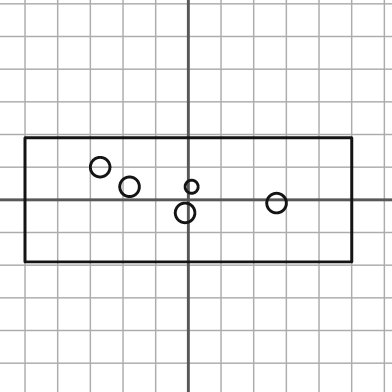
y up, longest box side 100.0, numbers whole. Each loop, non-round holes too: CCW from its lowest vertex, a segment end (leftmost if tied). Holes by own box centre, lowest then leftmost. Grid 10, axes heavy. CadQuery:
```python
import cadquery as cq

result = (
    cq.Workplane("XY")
    .moveTo(-50.0, -19.0)
    .lineTo(50.0, -19.0)
    .lineTo(50.0, 19.0)
    .lineTo(-50.0, 19.0)
    .close()
    .moveTo(-1.0, -4.0)
    .circle(3.0)
    .moveTo(27.0, -1.0)
    .circle(3.0)
    .moveTo(-18.0, 4.0)
    .circle(3.0)
    .moveTo(1.0, 4.0)
    .circle(2.0)
    .moveTo(-27.0, 10.0)
    .circle(3.0)
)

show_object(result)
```